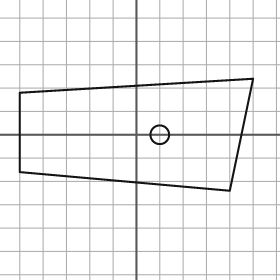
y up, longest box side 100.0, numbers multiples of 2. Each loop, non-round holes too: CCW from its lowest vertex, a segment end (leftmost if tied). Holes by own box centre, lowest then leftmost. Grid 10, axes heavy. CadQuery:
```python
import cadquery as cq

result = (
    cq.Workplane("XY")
    .moveTo(40.0, -24.0)
    .lineTo(50.0, 24.0)
    .lineTo(-50.0, 18.0)
    .lineTo(-50.0, -16.0)
    .close()
    .moveTo(10.0, 0.0)
    .circle(4.0)
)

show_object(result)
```